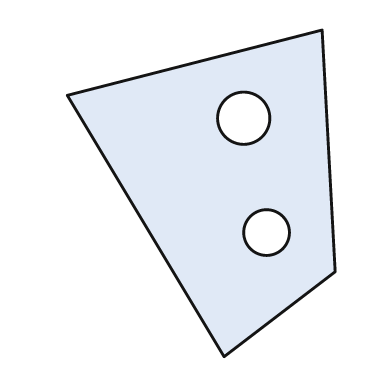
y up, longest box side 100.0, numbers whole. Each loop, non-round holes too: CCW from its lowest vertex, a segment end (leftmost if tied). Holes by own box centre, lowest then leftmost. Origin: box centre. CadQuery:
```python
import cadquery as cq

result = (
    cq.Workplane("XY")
    .moveTo(7.0, -50.0)
    .lineTo(41.0, -24.0)
    .lineTo(37.0, 50.0)
    .lineTo(-41.0, 30.0)
    .close()
    .moveTo(20.0, -12.0)
    .circle(7.0)
    .moveTo(13.0, 23.0)
    .circle(8.0)
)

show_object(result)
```